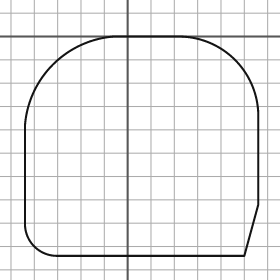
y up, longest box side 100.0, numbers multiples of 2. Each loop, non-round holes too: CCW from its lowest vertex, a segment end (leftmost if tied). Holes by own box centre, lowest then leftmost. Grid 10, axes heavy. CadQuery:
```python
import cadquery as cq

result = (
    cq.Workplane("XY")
    .moveTo(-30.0, -94.0)
    .lineTo(50.0, -94.0)
    .lineTo(56.0, -72.0)
    .lineTo(56.0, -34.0)
    .threePointArc((46.0, -10.0), (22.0, 0.0))
    .lineTo(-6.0, 0.0)
    .threePointArc((-32.0, -12.0), (-44.0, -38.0))
    .lineTo(-44.0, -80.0)
    .threePointArc((-40.0, -90.0), (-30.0, -94.0))
    .close()
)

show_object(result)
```